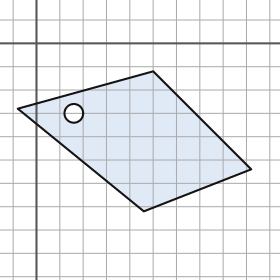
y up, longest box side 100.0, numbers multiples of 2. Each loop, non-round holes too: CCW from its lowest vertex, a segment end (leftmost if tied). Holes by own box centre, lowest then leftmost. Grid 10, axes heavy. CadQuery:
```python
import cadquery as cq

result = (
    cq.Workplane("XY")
    .moveTo(46.0, -72.0)
    .lineTo(92.0, -54.0)
    .lineTo(50.0, -12.0)
    .lineTo(-8.0, -28.0)
    .close()
    .moveTo(16.0, -30.0)
    .circle(4.0)
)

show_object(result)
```